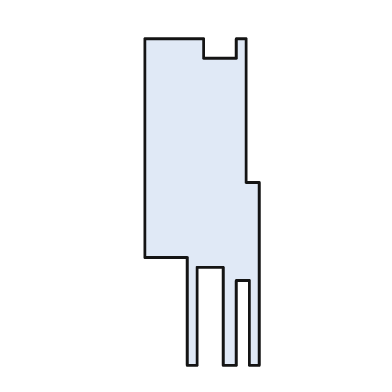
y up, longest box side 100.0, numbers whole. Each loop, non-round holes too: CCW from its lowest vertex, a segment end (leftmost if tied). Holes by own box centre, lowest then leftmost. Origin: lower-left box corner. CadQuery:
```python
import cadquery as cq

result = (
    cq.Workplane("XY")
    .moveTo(13.0, 0.0)
    .lineTo(16.0, 0.0)
    .lineTo(16.0, 30.0)
    .lineTo(24.0, 30.0)
    .lineTo(24.0, 0.0)
    .lineTo(28.0, 0.0)
    .lineTo(28.0, 26.0)
    .lineTo(32.0, 26.0)
    .lineTo(32.0, 0.0)
    .lineTo(35.0, 0.0)
    .lineTo(35.0, 56.0)
    .lineTo(31.0, 56.0)
    .lineTo(31.0, 100.0)
    .lineTo(28.0, 100.0)
    .lineTo(28.0, 94.0)
    .lineTo(18.0, 94.0)
    .lineTo(18.0, 100.0)
    .lineTo(0.0, 100.0)
    .lineTo(0.0, 33.0)
    .lineTo(13.0, 33.0)
    .close()
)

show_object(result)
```